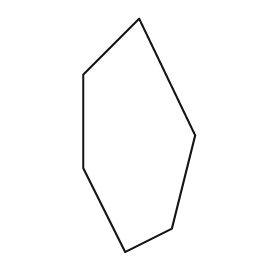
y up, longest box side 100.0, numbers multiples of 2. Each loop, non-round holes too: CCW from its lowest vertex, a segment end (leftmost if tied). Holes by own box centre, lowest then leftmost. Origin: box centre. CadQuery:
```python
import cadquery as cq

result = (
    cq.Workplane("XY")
    .moveTo(-6.0, -50.0)
    .lineTo(14.0, -40.0)
    .lineTo(24.0, 0.0)
    .lineTo(0.0, 50.0)
    .lineTo(-24.0, 26.0)
    .lineTo(-24.0, -14.0)
    .close()
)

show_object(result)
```